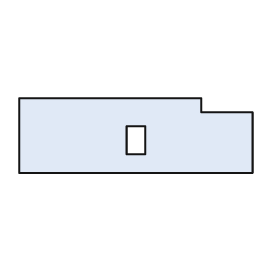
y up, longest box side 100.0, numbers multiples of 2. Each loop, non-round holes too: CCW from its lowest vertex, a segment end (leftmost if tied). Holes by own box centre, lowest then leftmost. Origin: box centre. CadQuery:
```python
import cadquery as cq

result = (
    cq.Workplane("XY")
    .moveTo(-50.0, -16.0)
    .lineTo(50.0, -16.0)
    .lineTo(50.0, 10.0)
    .lineTo(28.0, 10.0)
    .lineTo(28.0, 16.0)
    .lineTo(-50.0, 16.0)
    .close()
    .moveTo(-4.0, -8.0)
    .lineTo(4.0, -8.0)
    .lineTo(4.0, 4.0)
    .lineTo(-4.0, 4.0)
    .close()
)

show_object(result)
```